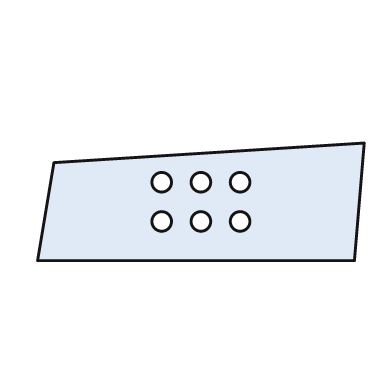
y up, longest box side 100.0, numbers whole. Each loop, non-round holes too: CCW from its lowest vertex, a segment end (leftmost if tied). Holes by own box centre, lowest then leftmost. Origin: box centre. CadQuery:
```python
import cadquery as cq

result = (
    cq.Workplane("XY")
    .moveTo(-50.0, -18.0)
    .lineTo(47.0, -18.0)
    .lineTo(50.0, 18.0)
    .lineTo(-45.0, 12.0)
    .close()
    .moveTo(-12.0, -6.0)
    .circle(3.0)
    .moveTo(0.0, -6.0)
    .circle(3.0)
    .moveTo(12.0, -6.0)
    .circle(3.0)
    .moveTo(-12.0, 6.0)
    .circle(3.0)
    .moveTo(0.0, 6.0)
    .circle(3.0)
    .moveTo(12.0, 6.0)
    .circle(3.0)
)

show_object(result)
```